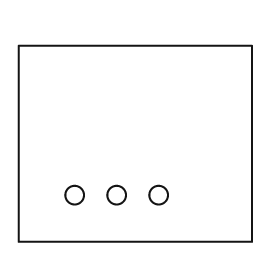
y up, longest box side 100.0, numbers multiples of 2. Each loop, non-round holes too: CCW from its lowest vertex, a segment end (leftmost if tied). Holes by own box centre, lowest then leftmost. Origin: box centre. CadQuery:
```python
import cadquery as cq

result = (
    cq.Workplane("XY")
    .moveTo(-50.0, -42.0)
    .lineTo(50.0, -42.0)
    .lineTo(50.0, 42.0)
    .lineTo(-50.0, 42.0)
    .close()
    .moveTo(-26.0, -22.0)
    .circle(4.0)
    .moveTo(-8.0, -22.0)
    .circle(4.0)
    .moveTo(10.0, -22.0)
    .circle(4.0)
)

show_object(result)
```